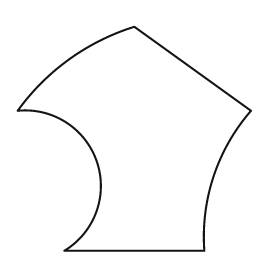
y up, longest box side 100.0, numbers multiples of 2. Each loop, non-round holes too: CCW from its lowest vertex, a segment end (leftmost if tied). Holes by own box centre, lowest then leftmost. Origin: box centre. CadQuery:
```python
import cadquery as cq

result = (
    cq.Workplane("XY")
    .moveTo(-30.0, -48.0)
    .lineTo(30.0, -48.0)
    .threePointArc((34.0, -16.0), (50.0, 12.0))
    .lineTo(0.0, 48.0)
    .threePointArc((-28.0, 34.0), (-50.0, 12.0))
    .threePointArc((-16.0, -10.0), (-30.0, -48.0))
    .close()
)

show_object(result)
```